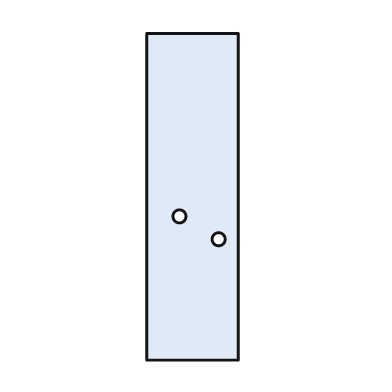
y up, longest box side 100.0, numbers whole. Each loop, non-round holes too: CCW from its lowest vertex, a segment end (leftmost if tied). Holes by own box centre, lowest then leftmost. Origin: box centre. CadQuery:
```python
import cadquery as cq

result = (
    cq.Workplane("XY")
    .moveTo(-14.0, -50.0)
    .lineTo(14.0, -50.0)
    .lineTo(14.0, 50.0)
    .lineTo(-14.0, 50.0)
    .close()
    .moveTo(8.0, -13.0)
    .circle(2.0)
    .moveTo(-4.0, -6.0)
    .circle(2.0)
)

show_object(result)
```